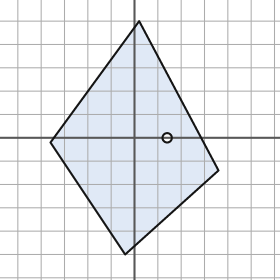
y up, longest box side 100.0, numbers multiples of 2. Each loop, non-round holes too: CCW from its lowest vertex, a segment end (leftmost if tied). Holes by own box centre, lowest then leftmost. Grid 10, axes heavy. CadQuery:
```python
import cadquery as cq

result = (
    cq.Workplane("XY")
    .moveTo(-4.0, -50.0)
    .lineTo(36.0, -14.0)
    .lineTo(2.0, 50.0)
    .lineTo(-36.0, -2.0)
    .close()
    .moveTo(14.0, 0.0)
    .circle(2.0)
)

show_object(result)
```